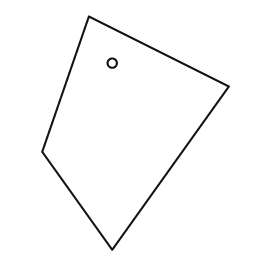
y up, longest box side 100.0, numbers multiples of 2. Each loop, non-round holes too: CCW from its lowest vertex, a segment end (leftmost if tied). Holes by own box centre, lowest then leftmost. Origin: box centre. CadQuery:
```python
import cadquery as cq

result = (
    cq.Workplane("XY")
    .moveTo(-10.0, -50.0)
    .lineTo(40.0, 20.0)
    .lineTo(-20.0, 50.0)
    .lineTo(-40.0, -8.0)
    .close()
    .moveTo(-10.0, 30.0)
    .circle(2.0)
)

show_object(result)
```